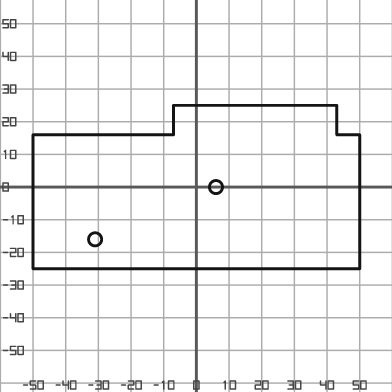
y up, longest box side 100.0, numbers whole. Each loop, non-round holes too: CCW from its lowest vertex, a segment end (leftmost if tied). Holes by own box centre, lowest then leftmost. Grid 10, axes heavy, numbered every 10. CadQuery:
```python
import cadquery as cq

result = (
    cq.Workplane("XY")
    .moveTo(-50.0, -25.0)
    .lineTo(50.0, -25.0)
    .lineTo(50.0, 16.0)
    .lineTo(43.0, 16.0)
    .lineTo(43.0, 25.0)
    .lineTo(-7.0, 25.0)
    .lineTo(-7.0, 16.0)
    .lineTo(-50.0, 16.0)
    .close()
    .moveTo(-31.0, -16.0)
    .circle(2.0)
    .moveTo(6.0, 0.0)
    .circle(2.0)
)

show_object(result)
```